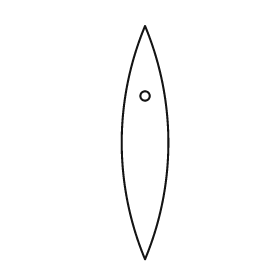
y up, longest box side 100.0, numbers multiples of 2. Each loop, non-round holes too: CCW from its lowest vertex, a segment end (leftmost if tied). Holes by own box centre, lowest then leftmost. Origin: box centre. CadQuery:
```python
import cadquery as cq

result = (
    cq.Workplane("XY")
    .moveTo(0.0, -50.0)
    .threePointArc((10.0, 0.0), (0.0, 50.0))
    .threePointArc((-10.0, 0.0), (0.0, -50.0))
    .close()
    .moveTo(0.0, 20.0)
    .circle(2.0)
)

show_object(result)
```